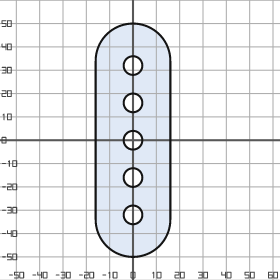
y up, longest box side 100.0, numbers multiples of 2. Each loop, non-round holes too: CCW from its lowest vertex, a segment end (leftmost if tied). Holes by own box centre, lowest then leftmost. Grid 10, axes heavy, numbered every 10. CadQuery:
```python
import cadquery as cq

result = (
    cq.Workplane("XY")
    .moveTo(-16.0, -34.0)
    .threePointArc((0.0, -50.0), (16.0, -34.0))
    .lineTo(16.0, 34.0)
    .threePointArc((0.0, 50.0), (-16.0, 34.0))
    .close()
    .moveTo(0.0, -32.0)
    .circle(4.0)
    .moveTo(0.0, -16.0)
    .circle(4.0)
    .moveTo(0.0, 0.0)
    .circle(4.0)
    .moveTo(0.0, 16.0)
    .circle(4.0)
    .moveTo(0.0, 32.0)
    .circle(4.0)
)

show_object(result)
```